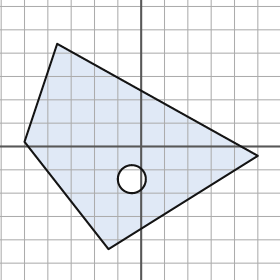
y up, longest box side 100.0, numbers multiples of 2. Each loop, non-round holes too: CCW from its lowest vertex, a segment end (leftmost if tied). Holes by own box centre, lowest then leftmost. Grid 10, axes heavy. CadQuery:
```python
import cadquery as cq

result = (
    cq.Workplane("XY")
    .moveTo(-14.0, -44.0)
    .lineTo(50.0, -4.0)
    .lineTo(-36.0, 44.0)
    .lineTo(-50.0, 2.0)
    .close()
    .moveTo(-4.0, -14.0)
    .circle(6.0)
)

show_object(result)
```